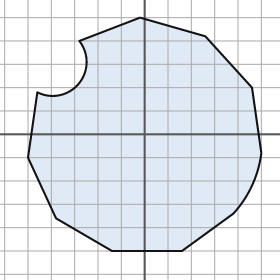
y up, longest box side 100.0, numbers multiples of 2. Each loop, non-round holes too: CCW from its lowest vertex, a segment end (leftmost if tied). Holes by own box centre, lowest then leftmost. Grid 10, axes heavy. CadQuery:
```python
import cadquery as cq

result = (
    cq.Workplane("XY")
    .moveTo(-14.0, -50.0)
    .lineTo(16.0, -50.0)
    .lineTo(38.0, -34.0)
    .threePointArc((46.0, -22.0), (50.0, -8.0))
    .lineTo(46.0, 20.0)
    .lineTo(26.0, 42.0)
    .lineTo(-2.0, 50.0)
    .lineTo(-28.0, 40.0)
    .threePointArc((-28.0, 22.0), (-46.0, 18.0))
    .lineTo(-50.0, -10.0)
    .lineTo(-38.0, -36.0)
    .close()
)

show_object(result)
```